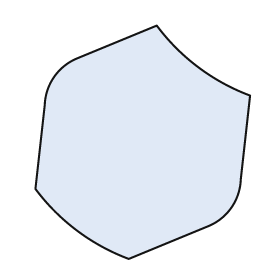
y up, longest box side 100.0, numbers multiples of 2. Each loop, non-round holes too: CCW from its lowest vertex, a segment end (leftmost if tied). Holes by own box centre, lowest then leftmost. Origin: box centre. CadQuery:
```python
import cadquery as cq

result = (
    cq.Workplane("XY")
    .moveTo(-6.0, -50.0)
    .lineTo(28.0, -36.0)
    .threePointArc((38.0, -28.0), (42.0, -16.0))
    .lineTo(46.0, 20.0)
    .threePointArc((24.0, 32.0), (6.0, 50.0))
    .lineTo(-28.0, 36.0)
    .threePointArc((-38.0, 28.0), (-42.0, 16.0))
    .lineTo(-46.0, -20.0)
    .threePointArc((-28.0, -38.0), (-6.0, -50.0))
    .close()
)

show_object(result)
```